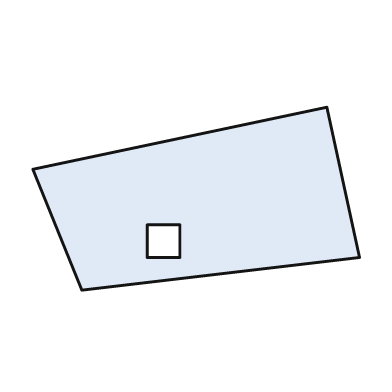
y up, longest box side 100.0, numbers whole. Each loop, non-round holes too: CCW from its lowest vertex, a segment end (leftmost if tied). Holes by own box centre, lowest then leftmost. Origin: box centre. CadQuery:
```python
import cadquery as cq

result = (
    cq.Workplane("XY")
    .moveTo(-35.0, -28.0)
    .lineTo(50.0, -18.0)
    .lineTo(40.0, 28.0)
    .lineTo(-50.0, 9.0)
    .close()
    .moveTo(-15.0, -18.0)
    .lineTo(-5.0, -18.0)
    .lineTo(-5.0, -8.0)
    .lineTo(-15.0, -8.0)
    .close()
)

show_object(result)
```